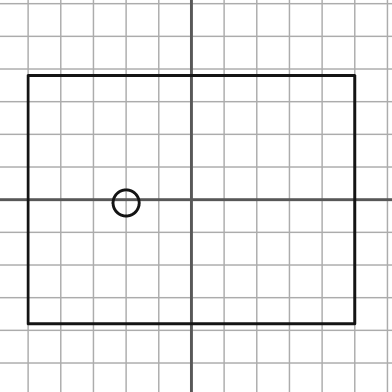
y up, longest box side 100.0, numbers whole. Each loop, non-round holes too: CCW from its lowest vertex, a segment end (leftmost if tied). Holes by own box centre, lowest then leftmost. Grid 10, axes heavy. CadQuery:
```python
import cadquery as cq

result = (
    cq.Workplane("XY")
    .moveTo(-50.0, -38.0)
    .lineTo(50.0, -38.0)
    .lineTo(50.0, 38.0)
    .lineTo(-50.0, 38.0)
    .close()
    .moveTo(-20.0, -1.0)
    .circle(4.0)
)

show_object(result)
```